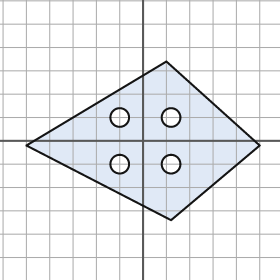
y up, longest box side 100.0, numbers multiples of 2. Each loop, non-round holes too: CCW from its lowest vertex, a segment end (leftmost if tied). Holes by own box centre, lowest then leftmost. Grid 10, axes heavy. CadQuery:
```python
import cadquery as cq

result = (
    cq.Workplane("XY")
    .moveTo(12.0, -34.0)
    .lineTo(50.0, -2.0)
    .lineTo(10.0, 34.0)
    .lineTo(-50.0, -2.0)
    .close()
    .moveTo(-10.0, -10.0)
    .circle(4.0)
    .moveTo(12.0, -10.0)
    .circle(4.0)
    .moveTo(-10.0, 10.0)
    .circle(4.0)
    .moveTo(12.0, 10.0)
    .circle(4.0)
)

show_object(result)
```